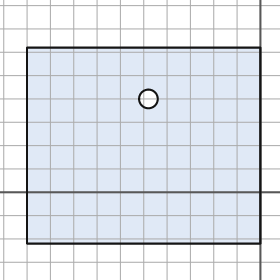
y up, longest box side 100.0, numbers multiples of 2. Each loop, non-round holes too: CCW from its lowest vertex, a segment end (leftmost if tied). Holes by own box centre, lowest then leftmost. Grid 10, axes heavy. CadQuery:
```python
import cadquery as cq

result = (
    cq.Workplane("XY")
    .moveTo(-100.0, -22.0)
    .lineTo(0.0, -22.0)
    .lineTo(0.0, 62.0)
    .lineTo(-100.0, 62.0)
    .close()
    .moveTo(-48.0, 40.0)
    .circle(4.0)
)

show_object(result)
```